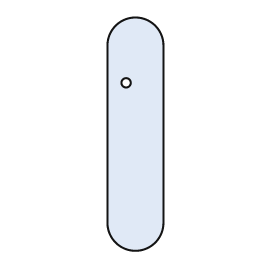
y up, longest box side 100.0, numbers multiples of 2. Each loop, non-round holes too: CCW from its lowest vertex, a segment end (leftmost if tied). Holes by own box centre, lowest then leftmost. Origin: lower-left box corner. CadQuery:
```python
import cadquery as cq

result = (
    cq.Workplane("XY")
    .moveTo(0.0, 12.0)
    .threePointArc((12.0, 0.0), (24.0, 12.0))
    .lineTo(24.0, 88.0)
    .threePointArc((12.0, 100.0), (0.0, 88.0))
    .close()
    .moveTo(8.0, 72.0)
    .circle(2.0)
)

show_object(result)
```